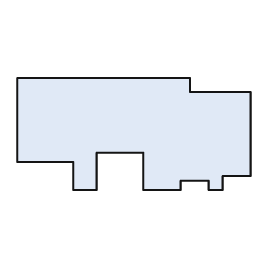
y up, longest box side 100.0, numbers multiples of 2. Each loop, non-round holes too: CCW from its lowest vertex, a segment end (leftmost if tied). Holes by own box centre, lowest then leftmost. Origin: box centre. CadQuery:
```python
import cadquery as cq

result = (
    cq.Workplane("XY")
    .moveTo(-26.0, -24.0)
    .lineTo(-16.0, -24.0)
    .lineTo(-16.0, -8.0)
    .lineTo(4.0, -8.0)
    .lineTo(4.0, -24.0)
    .lineTo(20.0, -24.0)
    .lineTo(20.0, -20.0)
    .lineTo(32.0, -20.0)
    .lineTo(32.0, -24.0)
    .lineTo(38.0, -24.0)
    .lineTo(38.0, -18.0)
    .lineTo(50.0, -18.0)
    .lineTo(50.0, 18.0)
    .lineTo(24.0, 18.0)
    .lineTo(24.0, 24.0)
    .lineTo(-50.0, 24.0)
    .lineTo(-50.0, -12.0)
    .lineTo(-26.0, -12.0)
    .close()
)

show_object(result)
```